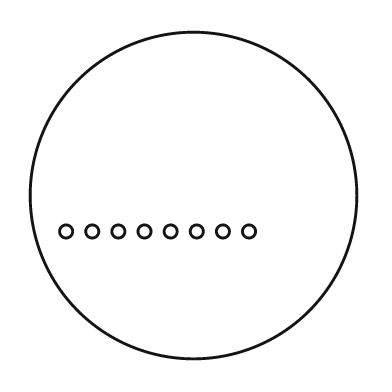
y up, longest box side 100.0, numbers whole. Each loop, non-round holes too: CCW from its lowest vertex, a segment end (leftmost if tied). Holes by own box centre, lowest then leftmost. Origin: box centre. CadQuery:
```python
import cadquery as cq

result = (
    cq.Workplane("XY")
    .moveTo(0.0, 0.0)
    .circle(50.0)
    .moveTo(-39.0, -11.0)
    .circle(2.0)
    .moveTo(-31.0, -11.0)
    .circle(2.0)
    .moveTo(-23.0, -11.0)
    .circle(2.0)
    .moveTo(-15.0, -11.0)
    .circle(2.0)
    .moveTo(-7.0, -11.0)
    .circle(2.0)
    .moveTo(1.0, -11.0)
    .circle(2.0)
    .moveTo(9.0, -11.0)
    .circle(2.0)
    .moveTo(17.0, -11.0)
    .circle(2.0)
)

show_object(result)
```